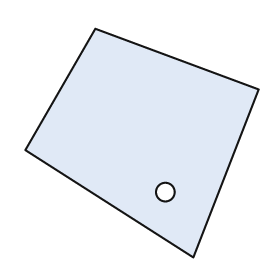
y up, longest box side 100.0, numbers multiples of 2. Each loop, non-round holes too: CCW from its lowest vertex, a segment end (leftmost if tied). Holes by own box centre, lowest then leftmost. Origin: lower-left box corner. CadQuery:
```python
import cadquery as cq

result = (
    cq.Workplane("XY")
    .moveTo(72.0, 0.0)
    .lineTo(100.0, 72.0)
    .lineTo(30.0, 98.0)
    .lineTo(0.0, 46.0)
    .close()
    .moveTo(60.0, 28.0)
    .circle(4.0)
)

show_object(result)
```